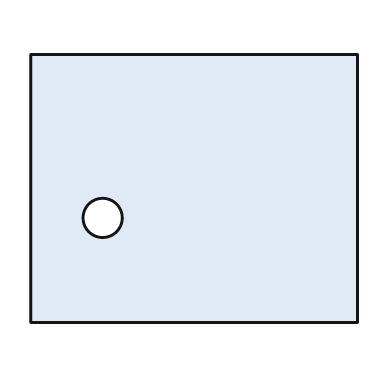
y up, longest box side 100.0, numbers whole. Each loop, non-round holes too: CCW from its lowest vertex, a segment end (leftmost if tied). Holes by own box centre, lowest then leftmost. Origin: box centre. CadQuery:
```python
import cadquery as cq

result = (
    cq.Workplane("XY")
    .moveTo(-50.0, -41.0)
    .lineTo(50.0, -41.0)
    .lineTo(50.0, 41.0)
    .lineTo(-50.0, 41.0)
    .close()
    .moveTo(-28.0, -9.0)
    .circle(6.0)
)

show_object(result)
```